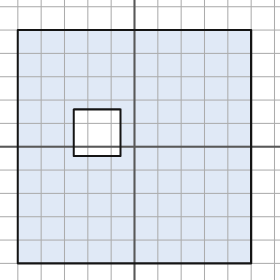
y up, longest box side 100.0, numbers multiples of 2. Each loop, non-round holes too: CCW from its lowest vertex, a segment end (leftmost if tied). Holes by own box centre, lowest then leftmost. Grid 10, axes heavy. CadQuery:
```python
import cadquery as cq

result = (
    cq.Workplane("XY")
    .moveTo(-50.0, -50.0)
    .lineTo(50.0, -50.0)
    .lineTo(50.0, 50.0)
    .lineTo(-50.0, 50.0)
    .close()
    .moveTo(-26.0, -4.0)
    .lineTo(-6.0, -4.0)
    .lineTo(-6.0, 16.0)
    .lineTo(-26.0, 16.0)
    .close()
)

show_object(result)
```